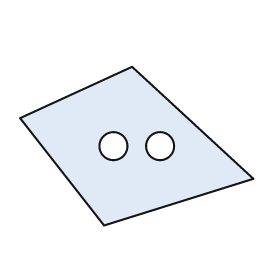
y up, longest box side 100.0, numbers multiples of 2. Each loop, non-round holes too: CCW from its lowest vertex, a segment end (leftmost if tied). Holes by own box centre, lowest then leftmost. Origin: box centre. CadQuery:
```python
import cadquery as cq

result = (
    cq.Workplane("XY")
    .moveTo(-14.0, -34.0)
    .lineTo(50.0, -14.0)
    .lineTo(-2.0, 34.0)
    .lineTo(-50.0, 12.0)
    .close()
    .moveTo(-10.0, 0.0)
    .circle(6.0)
    .moveTo(10.0, 0.0)
    .circle(6.0)
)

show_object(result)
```